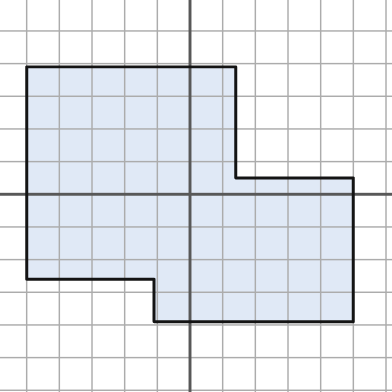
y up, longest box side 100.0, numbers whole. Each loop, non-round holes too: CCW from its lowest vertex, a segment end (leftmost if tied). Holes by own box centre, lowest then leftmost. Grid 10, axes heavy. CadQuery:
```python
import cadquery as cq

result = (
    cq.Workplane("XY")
    .moveTo(-11.0, -39.0)
    .lineTo(50.0, -39.0)
    .lineTo(50.0, 5.0)
    .lineTo(14.0, 5.0)
    .lineTo(14.0, 39.0)
    .lineTo(-50.0, 39.0)
    .lineTo(-50.0, -26.0)
    .lineTo(-11.0, -26.0)
    .close()
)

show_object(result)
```